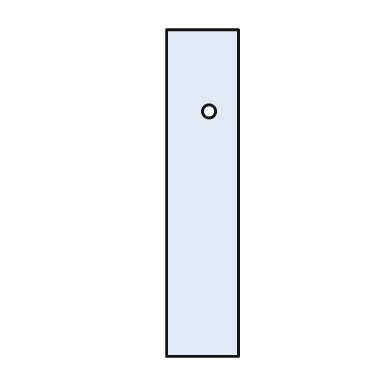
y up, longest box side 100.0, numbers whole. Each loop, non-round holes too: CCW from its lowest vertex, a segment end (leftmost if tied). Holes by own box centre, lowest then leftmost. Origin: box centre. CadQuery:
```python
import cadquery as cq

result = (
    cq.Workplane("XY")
    .moveTo(-11.0, -50.0)
    .lineTo(11.0, -50.0)
    .lineTo(11.0, 50.0)
    .lineTo(-11.0, 50.0)
    .close()
    .moveTo(2.0, 25.0)
    .circle(2.0)
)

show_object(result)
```